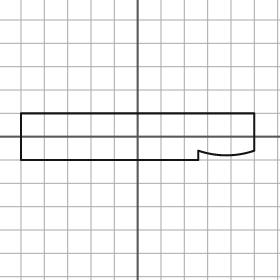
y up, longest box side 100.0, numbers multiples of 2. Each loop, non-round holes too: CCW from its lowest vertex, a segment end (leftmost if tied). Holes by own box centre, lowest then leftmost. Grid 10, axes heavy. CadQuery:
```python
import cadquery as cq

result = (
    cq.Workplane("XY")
    .moveTo(-50.0, -10.0)
    .lineTo(26.0, -10.0)
    .lineTo(26.0, -6.0)
    .threePointArc((38.0, -8.0), (50.0, -6.0))
    .lineTo(50.0, 10.0)
    .lineTo(-50.0, 10.0)
    .close()
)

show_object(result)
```